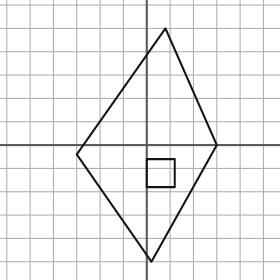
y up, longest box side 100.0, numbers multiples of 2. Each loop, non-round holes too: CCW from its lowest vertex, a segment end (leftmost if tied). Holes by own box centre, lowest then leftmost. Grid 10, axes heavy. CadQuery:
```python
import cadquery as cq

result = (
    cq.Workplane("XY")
    .moveTo(2.0, -50.0)
    .lineTo(30.0, 0.0)
    .lineTo(8.0, 50.0)
    .lineTo(-30.0, -4.0)
    .close()
    .moveTo(0.0, -18.0)
    .lineTo(12.0, -18.0)
    .lineTo(12.0, -6.0)
    .lineTo(0.0, -6.0)
    .close()
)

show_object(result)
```